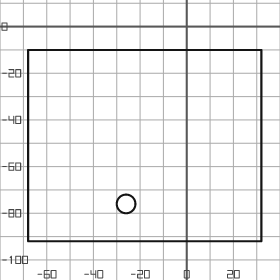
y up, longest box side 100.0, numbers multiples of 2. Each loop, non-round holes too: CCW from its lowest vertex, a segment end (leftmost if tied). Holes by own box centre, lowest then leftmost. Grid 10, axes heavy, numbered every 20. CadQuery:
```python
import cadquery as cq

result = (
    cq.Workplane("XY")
    .moveTo(-68.0, -92.0)
    .lineTo(32.0, -92.0)
    .lineTo(32.0, -10.0)
    .lineTo(-68.0, -10.0)
    .close()
    .moveTo(-26.0, -76.0)
    .circle(4.0)
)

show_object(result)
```